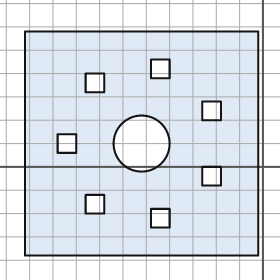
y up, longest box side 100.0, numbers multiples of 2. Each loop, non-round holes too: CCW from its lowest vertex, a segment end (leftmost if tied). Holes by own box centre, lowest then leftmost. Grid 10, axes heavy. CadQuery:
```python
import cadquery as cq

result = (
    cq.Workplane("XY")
    .moveTo(-102.0, -38.0)
    .lineTo(-2.0, -38.0)
    .lineTo(-2.0, 58.0)
    .lineTo(-102.0, 58.0)
    .close()
    .moveTo(-48.0, -26.0)
    .lineTo(-40.0, -26.0)
    .lineTo(-40.0, -18.0)
    .lineTo(-48.0, -18.0)
    .close()
    .moveTo(-76.0, -20.0)
    .lineTo(-68.0, -20.0)
    .lineTo(-68.0, -12.0)
    .lineTo(-76.0, -12.0)
    .close()
    .moveTo(-26.0, -8.0)
    .lineTo(-18.0, -8.0)
    .lineTo(-18.0, 0.0)
    .lineTo(-26.0, 0.0)
    .close()
    .moveTo(-88.0, 6.0)
    .lineTo(-80.0, 6.0)
    .lineTo(-80.0, 14.0)
    .lineTo(-88.0, 14.0)
    .close()
    .moveTo(-52.0, 10.0)
    .circle(12.0)
    .moveTo(-26.0, 20.0)
    .lineTo(-18.0, 20.0)
    .lineTo(-18.0, 28.0)
    .lineTo(-26.0, 28.0)
    .close()
    .moveTo(-76.0, 32.0)
    .lineTo(-68.0, 32.0)
    .lineTo(-68.0, 40.0)
    .lineTo(-76.0, 40.0)
    .close()
    .moveTo(-48.0, 38.0)
    .lineTo(-40.0, 38.0)
    .lineTo(-40.0, 46.0)
    .lineTo(-48.0, 46.0)
    .close()
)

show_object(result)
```